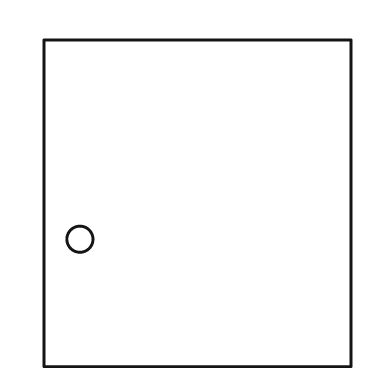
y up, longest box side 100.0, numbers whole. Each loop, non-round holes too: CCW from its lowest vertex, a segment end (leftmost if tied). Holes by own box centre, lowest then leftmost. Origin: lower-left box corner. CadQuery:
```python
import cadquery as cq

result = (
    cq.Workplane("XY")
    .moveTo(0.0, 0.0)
    .lineTo(94.0, 0.0)
    .lineTo(94.0, 100.0)
    .lineTo(0.0, 100.0)
    .close()
    .moveTo(11.0, 39.0)
    .circle(4.0)
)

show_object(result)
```